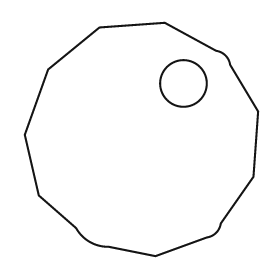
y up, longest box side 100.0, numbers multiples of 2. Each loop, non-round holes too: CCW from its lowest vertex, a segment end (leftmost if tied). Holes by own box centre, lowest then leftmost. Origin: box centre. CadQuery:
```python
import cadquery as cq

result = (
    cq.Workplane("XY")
    .moveTo(6.0, -50.0)
    .lineTo(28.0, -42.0)
    .threePointArc((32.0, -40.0), (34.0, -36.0))
    .lineTo(48.0, -16.0)
    .lineTo(50.0, 12.0)
    .lineTo(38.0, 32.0)
    .threePointArc((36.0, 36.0), (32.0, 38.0))
    .lineTo(10.0, 50.0)
    .lineTo(-18.0, 48.0)
    .lineTo(-40.0, 30.0)
    .lineTo(-50.0, 2.0)
    .lineTo(-44.0, -24.0)
    .lineTo(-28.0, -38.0)
    .threePointArc((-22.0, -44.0), (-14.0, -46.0))
    .close()
    .moveTo(18.0, 24.0)
    .circle(10.0)
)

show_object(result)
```